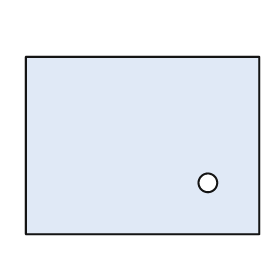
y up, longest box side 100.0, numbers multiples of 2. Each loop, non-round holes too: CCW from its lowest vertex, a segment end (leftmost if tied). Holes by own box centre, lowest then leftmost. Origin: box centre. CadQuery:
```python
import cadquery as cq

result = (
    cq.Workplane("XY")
    .moveTo(-50.0, -38.0)
    .lineTo(50.0, -38.0)
    .lineTo(50.0, 38.0)
    .lineTo(-50.0, 38.0)
    .close()
    .moveTo(28.0, -16.0)
    .circle(4.0)
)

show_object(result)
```